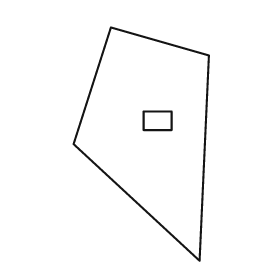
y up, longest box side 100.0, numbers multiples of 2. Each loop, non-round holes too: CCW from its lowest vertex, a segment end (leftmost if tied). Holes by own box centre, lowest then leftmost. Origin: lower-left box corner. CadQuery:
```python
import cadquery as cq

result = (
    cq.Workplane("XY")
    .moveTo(54.0, 0.0)
    .lineTo(58.0, 88.0)
    .lineTo(16.0, 100.0)
    .lineTo(0.0, 50.0)
    .close()
    .moveTo(30.0, 56.0)
    .lineTo(42.0, 56.0)
    .lineTo(42.0, 64.0)
    .lineTo(30.0, 64.0)
    .close()
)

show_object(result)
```